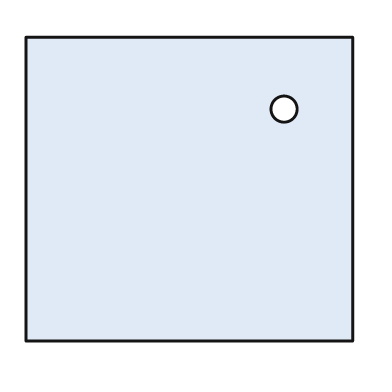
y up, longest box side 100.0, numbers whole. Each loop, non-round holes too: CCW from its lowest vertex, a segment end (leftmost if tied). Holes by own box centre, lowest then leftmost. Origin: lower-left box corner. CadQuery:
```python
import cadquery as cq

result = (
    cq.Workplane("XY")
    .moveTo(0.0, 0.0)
    .lineTo(100.0, 0.0)
    .lineTo(100.0, 93.0)
    .lineTo(0.0, 93.0)
    .close()
    .moveTo(79.0, 71.0)
    .circle(4.0)
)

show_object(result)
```